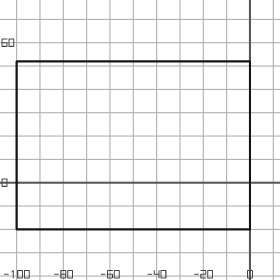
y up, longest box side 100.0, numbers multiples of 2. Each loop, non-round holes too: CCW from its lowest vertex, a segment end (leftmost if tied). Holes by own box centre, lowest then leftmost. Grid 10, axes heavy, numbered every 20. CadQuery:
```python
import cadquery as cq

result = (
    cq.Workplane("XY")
    .moveTo(-100.0, -20.0)
    .lineTo(0.0, -20.0)
    .lineTo(0.0, 52.0)
    .lineTo(-100.0, 52.0)
    .close()
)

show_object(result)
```